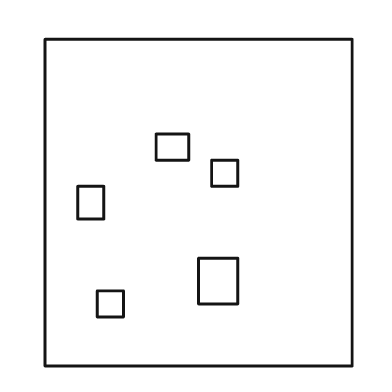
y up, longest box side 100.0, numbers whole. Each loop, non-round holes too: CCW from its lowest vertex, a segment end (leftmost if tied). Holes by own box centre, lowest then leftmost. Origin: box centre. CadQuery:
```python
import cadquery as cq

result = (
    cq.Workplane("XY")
    .moveTo(-47.0, -50.0)
    .lineTo(47.0, -50.0)
    .lineTo(47.0, 50.0)
    .lineTo(-47.0, 50.0)
    .close()
    .moveTo(-31.0, -35.0)
    .lineTo(-23.0, -35.0)
    .lineTo(-23.0, -27.0)
    .lineTo(-31.0, -27.0)
    .close()
    .moveTo(0.0, -31.0)
    .lineTo(12.0, -31.0)
    .lineTo(12.0, -17.0)
    .lineTo(0.0, -17.0)
    .close()
    .moveTo(-37.0, -5.0)
    .lineTo(-29.0, -5.0)
    .lineTo(-29.0, 5.0)
    .lineTo(-37.0, 5.0)
    .close()
    .moveTo(4.0, 5.0)
    .lineTo(12.0, 5.0)
    .lineTo(12.0, 13.0)
    .lineTo(4.0, 13.0)
    .close()
    .moveTo(-13.0, 13.0)
    .lineTo(-3.0, 13.0)
    .lineTo(-3.0, 21.0)
    .lineTo(-13.0, 21.0)
    .close()
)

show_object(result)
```